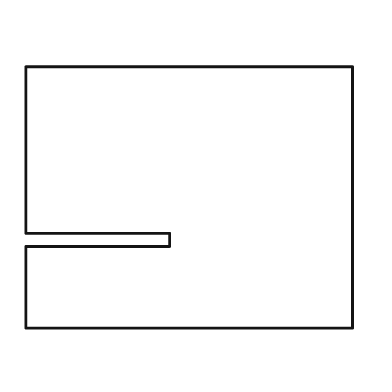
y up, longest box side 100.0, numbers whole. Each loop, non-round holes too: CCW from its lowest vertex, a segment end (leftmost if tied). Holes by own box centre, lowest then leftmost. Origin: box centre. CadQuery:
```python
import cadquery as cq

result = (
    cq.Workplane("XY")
    .moveTo(-50.0, -40.0)
    .lineTo(50.0, -40.0)
    .lineTo(50.0, 40.0)
    .lineTo(-50.0, 40.0)
    .lineTo(-50.0, -11.0)
    .lineTo(-6.0, -11.0)
    .lineTo(-6.0, -15.0)
    .lineTo(-50.0, -15.0)
    .close()
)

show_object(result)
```